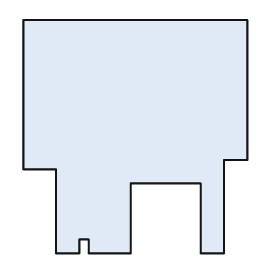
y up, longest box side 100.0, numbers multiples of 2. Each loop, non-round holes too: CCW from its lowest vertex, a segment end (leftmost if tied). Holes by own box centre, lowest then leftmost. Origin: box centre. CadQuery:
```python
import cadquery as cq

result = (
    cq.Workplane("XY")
    .moveTo(-34.0, -50.0)
    .lineTo(-24.0, -50.0)
    .lineTo(-24.0, -44.0)
    .lineTo(-20.0, -44.0)
    .lineTo(-20.0, -50.0)
    .lineTo(-2.0, -50.0)
    .lineTo(-2.0, -20.0)
    .lineTo(28.0, -20.0)
    .lineTo(28.0, -50.0)
    .lineTo(38.0, -50.0)
    .lineTo(38.0, -10.0)
    .lineTo(48.0, -10.0)
    .lineTo(48.0, 50.0)
    .lineTo(-48.0, 50.0)
    .lineTo(-48.0, -14.0)
    .lineTo(-34.0, -14.0)
    .close()
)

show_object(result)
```